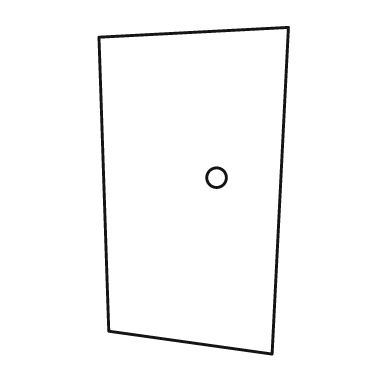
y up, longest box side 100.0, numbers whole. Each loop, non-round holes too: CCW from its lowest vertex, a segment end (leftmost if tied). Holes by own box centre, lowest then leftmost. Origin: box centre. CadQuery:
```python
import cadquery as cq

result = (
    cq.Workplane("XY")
    .moveTo(24.0, -50.0)
    .lineTo(29.0, 50.0)
    .lineTo(-29.0, 47.0)
    .lineTo(-26.0, -43.0)
    .close()
    .moveTo(7.0, 4.0)
    .circle(3.0)
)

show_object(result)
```